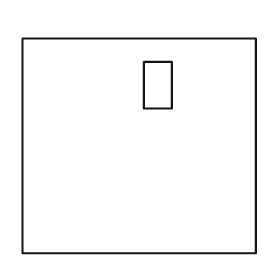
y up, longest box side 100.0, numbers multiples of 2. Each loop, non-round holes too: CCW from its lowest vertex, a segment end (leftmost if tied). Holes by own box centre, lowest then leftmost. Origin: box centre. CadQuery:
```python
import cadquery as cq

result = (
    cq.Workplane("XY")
    .moveTo(-50.0, -46.0)
    .lineTo(50.0, -46.0)
    .lineTo(50.0, 46.0)
    .lineTo(-50.0, 46.0)
    .close()
    .moveTo(2.0, 16.0)
    .lineTo(14.0, 16.0)
    .lineTo(14.0, 36.0)
    .lineTo(2.0, 36.0)
    .close()
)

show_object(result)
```